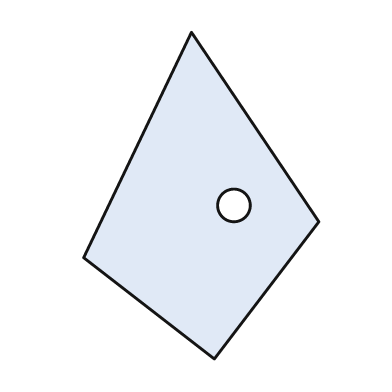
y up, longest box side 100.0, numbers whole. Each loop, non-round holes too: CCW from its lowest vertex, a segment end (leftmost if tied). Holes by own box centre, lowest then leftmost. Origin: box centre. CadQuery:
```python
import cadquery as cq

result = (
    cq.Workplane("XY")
    .moveTo(4.0, -50.0)
    .lineTo(36.0, -8.0)
    .lineTo(-3.0, 50.0)
    .lineTo(-36.0, -19.0)
    .close()
    .moveTo(10.0, -3.0)
    .circle(5.0)
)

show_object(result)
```